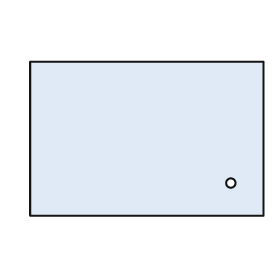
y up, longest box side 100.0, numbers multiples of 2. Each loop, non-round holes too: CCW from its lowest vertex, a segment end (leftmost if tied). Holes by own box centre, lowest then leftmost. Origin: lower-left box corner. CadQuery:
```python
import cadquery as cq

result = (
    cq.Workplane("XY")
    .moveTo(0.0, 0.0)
    .lineTo(100.0, 0.0)
    .lineTo(100.0, 66.0)
    .lineTo(0.0, 66.0)
    .close()
    .moveTo(86.0, 14.0)
    .circle(2.0)
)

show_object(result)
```